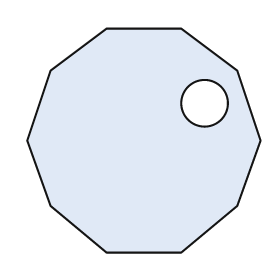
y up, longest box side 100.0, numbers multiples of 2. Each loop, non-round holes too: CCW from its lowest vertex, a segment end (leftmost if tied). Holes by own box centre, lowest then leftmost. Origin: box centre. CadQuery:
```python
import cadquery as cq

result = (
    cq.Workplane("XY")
    .moveTo(-16.0, -48.0)
    .lineTo(16.0, -48.0)
    .lineTo(40.0, -28.0)
    .lineTo(50.0, 0.0)
    .lineTo(40.0, 30.0)
    .lineTo(16.0, 48.0)
    .lineTo(-16.0, 48.0)
    .lineTo(-40.0, 30.0)
    .lineTo(-50.0, 0.0)
    .lineTo(-40.0, -28.0)
    .close()
    .moveTo(26.0, 16.0)
    .circle(10.0)
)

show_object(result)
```